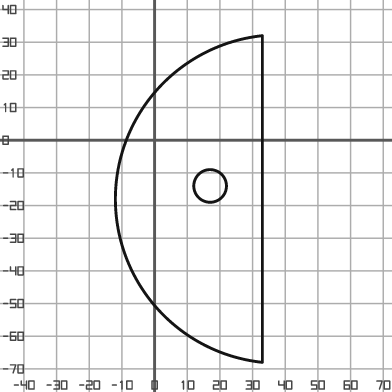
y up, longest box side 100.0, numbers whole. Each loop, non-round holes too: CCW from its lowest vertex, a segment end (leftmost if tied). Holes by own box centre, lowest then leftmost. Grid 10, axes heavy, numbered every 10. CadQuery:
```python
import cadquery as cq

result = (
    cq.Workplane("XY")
    .moveTo(33.0, -68.0)
    .lineTo(33.0, 32.0)
    .threePointArc((-12.0, -18.0), (33.0, -68.0))
    .close()
    .moveTo(17.0, -14.0)
    .circle(5.0)
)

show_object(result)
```